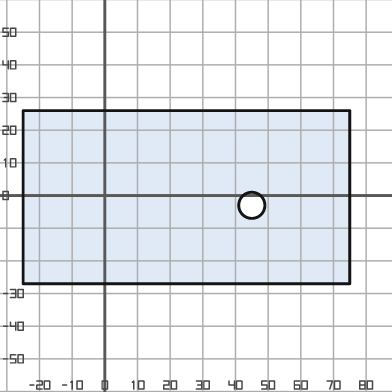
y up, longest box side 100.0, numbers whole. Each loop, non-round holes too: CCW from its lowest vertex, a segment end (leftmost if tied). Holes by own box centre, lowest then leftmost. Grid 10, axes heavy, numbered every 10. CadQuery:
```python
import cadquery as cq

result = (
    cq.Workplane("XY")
    .moveTo(-25.0, -27.0)
    .lineTo(75.0, -27.0)
    .lineTo(75.0, 26.0)
    .lineTo(-25.0, 26.0)
    .close()
    .moveTo(45.0, -3.0)
    .circle(4.0)
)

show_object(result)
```